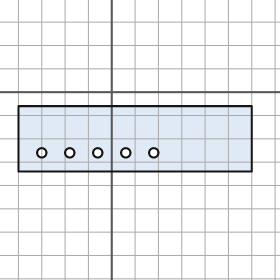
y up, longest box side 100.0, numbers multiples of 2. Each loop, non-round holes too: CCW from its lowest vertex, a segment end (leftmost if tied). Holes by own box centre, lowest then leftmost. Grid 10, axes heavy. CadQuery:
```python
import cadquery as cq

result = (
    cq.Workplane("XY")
    .moveTo(-40.0, -34.0)
    .lineTo(60.0, -34.0)
    .lineTo(60.0, -6.0)
    .lineTo(-40.0, -6.0)
    .close()
    .moveTo(-30.0, -26.0)
    .circle(2.0)
    .moveTo(-18.0, -26.0)
    .circle(2.0)
    .moveTo(-6.0, -26.0)
    .circle(2.0)
    .moveTo(6.0, -26.0)
    .circle(2.0)
    .moveTo(18.0, -26.0)
    .circle(2.0)
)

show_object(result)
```